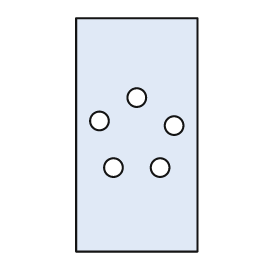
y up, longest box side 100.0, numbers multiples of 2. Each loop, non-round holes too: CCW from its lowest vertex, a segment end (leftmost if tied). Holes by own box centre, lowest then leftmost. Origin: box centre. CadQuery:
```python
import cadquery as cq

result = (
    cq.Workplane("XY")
    .moveTo(-26.0, -50.0)
    .lineTo(26.0, -50.0)
    .lineTo(26.0, 50.0)
    .lineTo(-26.0, 50.0)
    .close()
    .moveTo(-10.0, -14.0)
    .circle(4.0)
    .moveTo(10.0, -14.0)
    .circle(4.0)
    .moveTo(16.0, 4.0)
    .circle(4.0)
    .moveTo(-16.0, 6.0)
    .circle(4.0)
    .moveTo(0.0, 16.0)
    .circle(4.0)
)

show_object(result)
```